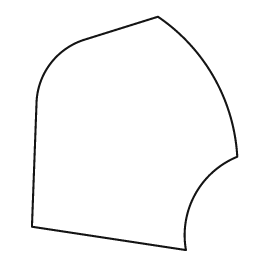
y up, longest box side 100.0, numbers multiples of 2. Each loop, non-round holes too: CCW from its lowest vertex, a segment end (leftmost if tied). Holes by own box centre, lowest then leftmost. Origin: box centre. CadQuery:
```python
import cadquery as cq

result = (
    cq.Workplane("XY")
    .moveTo(22.0, -50.0)
    .threePointArc((26.0, -26.0), (44.0, -10.0))
    .threePointArc((34.0, 24.0), (10.0, 50.0))
    .lineTo(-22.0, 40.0)
    .threePointArc((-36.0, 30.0), (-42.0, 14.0))
    .lineTo(-44.0, -40.0)
    .close()
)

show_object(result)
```